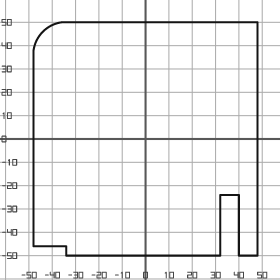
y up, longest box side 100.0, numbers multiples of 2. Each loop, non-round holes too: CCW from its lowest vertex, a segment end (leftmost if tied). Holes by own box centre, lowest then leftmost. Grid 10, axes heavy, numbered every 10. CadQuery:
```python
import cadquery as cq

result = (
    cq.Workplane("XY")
    .moveTo(-34.0, -50.0)
    .lineTo(32.0, -50.0)
    .lineTo(32.0, -24.0)
    .lineTo(40.0, -24.0)
    .lineTo(40.0, -50.0)
    .lineTo(48.0, -50.0)
    .lineTo(48.0, 50.0)
    .lineTo(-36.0, 50.0)
    .threePointArc((-44.0, 46.0), (-48.0, 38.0))
    .lineTo(-48.0, -46.0)
    .lineTo(-34.0, -46.0)
    .close()
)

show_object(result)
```